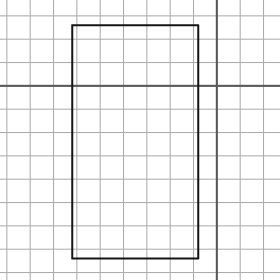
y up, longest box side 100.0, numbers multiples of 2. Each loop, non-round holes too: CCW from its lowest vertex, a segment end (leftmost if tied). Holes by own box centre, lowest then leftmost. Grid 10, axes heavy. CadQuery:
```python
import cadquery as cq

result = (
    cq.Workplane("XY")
    .moveTo(-62.0, -74.0)
    .lineTo(-8.0, -74.0)
    .lineTo(-8.0, 26.0)
    .lineTo(-62.0, 26.0)
    .close()
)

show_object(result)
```